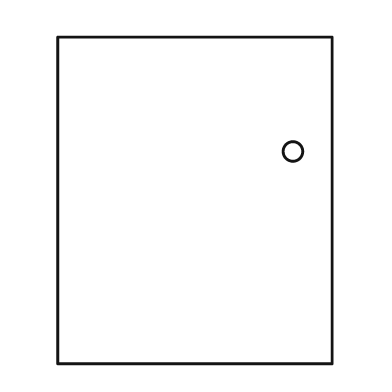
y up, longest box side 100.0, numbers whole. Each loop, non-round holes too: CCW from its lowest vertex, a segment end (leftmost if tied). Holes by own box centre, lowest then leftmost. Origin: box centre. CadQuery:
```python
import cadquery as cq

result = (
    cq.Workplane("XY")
    .moveTo(-42.0, -50.0)
    .lineTo(42.0, -50.0)
    .lineTo(42.0, 50.0)
    .lineTo(-42.0, 50.0)
    .close()
    .moveTo(30.0, 15.0)
    .circle(3.0)
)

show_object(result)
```